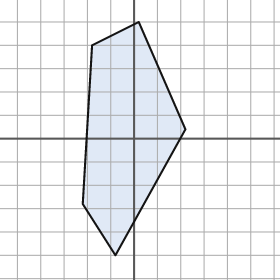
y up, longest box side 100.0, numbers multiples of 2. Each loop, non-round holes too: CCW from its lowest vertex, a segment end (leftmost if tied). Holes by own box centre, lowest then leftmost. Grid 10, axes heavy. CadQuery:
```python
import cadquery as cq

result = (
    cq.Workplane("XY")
    .moveTo(-8.0, -50.0)
    .lineTo(22.0, 4.0)
    .lineTo(2.0, 50.0)
    .lineTo(-18.0, 40.0)
    .lineTo(-22.0, -28.0)
    .close()
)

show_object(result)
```